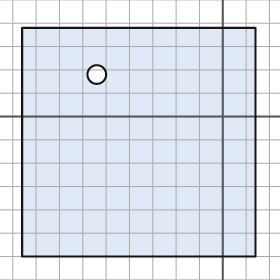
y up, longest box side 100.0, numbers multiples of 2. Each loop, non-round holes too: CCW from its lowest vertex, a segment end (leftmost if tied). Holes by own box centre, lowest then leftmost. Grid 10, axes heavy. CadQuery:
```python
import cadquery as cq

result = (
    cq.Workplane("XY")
    .moveTo(-86.0, -60.0)
    .lineTo(14.0, -60.0)
    .lineTo(14.0, 38.0)
    .lineTo(-86.0, 38.0)
    .close()
    .moveTo(-54.0, 18.0)
    .circle(4.0)
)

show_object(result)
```